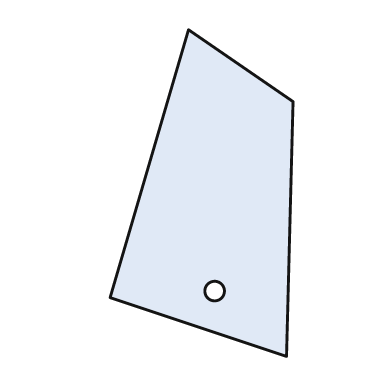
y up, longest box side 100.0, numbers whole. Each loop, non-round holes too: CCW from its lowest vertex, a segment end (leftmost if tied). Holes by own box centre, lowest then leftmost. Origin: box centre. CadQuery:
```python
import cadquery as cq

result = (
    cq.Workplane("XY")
    .moveTo(26.0, -50.0)
    .lineTo(28.0, 28.0)
    .lineTo(-4.0, 50.0)
    .lineTo(-28.0, -32.0)
    .close()
    .moveTo(4.0, -30.0)
    .circle(3.0)
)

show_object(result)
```